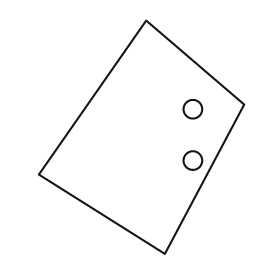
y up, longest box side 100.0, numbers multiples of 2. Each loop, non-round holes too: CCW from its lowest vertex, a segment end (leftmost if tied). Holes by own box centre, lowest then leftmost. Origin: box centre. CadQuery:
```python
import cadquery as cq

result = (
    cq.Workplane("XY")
    .moveTo(10.0, -50.0)
    .lineTo(44.0, 14.0)
    .lineTo(2.0, 50.0)
    .lineTo(-44.0, -16.0)
    .close()
    .moveTo(22.0, -10.0)
    .circle(4.0)
    .moveTo(22.0, 12.0)
    .circle(4.0)
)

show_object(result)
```